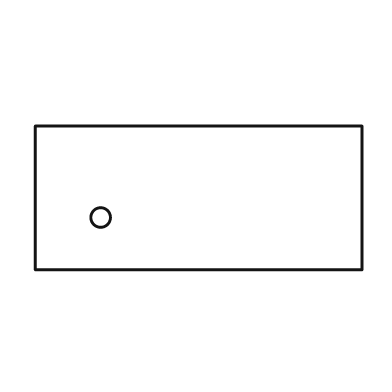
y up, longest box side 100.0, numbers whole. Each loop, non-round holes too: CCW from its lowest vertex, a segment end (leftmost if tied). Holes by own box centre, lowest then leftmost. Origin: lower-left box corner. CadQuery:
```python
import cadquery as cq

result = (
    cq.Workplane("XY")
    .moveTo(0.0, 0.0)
    .lineTo(100.0, 0.0)
    .lineTo(100.0, 44.0)
    .lineTo(0.0, 44.0)
    .close()
    .moveTo(20.0, 16.0)
    .circle(3.0)
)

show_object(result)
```